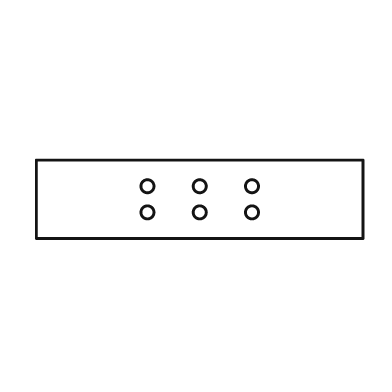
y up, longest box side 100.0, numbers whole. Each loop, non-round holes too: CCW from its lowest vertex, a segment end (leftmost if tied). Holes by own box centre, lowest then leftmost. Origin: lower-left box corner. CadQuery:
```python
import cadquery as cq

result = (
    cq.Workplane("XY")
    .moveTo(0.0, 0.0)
    .lineTo(100.0, 0.0)
    .lineTo(100.0, 24.0)
    .lineTo(0.0, 24.0)
    .close()
    .moveTo(34.0, 8.0)
    .circle(2.0)
    .moveTo(50.0, 8.0)
    .circle(2.0)
    .moveTo(66.0, 8.0)
    .circle(2.0)
    .moveTo(34.0, 16.0)
    .circle(2.0)
    .moveTo(50.0, 16.0)
    .circle(2.0)
    .moveTo(66.0, 16.0)
    .circle(2.0)
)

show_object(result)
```